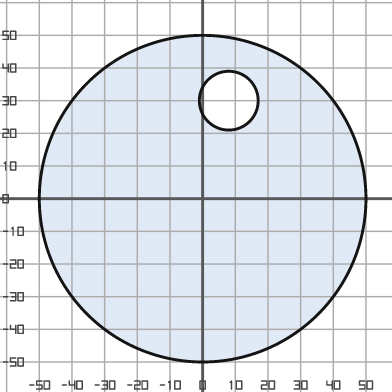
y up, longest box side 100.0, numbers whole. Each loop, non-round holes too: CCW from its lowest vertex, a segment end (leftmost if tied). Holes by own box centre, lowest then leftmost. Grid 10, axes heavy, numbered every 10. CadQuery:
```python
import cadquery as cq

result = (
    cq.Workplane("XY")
    .moveTo(0.0, 0.0)
    .circle(50.0)
    .moveTo(8.0, 30.0)
    .circle(9.0)
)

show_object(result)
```